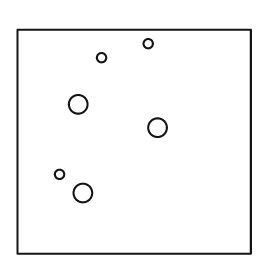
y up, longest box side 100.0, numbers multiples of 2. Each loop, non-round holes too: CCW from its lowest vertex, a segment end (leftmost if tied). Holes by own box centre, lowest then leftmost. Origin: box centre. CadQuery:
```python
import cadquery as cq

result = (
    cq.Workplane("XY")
    .moveTo(-50.0, -48.0)
    .lineTo(50.0, -48.0)
    .lineTo(50.0, 48.0)
    .lineTo(-50.0, 48.0)
    .close()
    .moveTo(-22.0, -22.0)
    .circle(4.0)
    .moveTo(-32.0, -14.0)
    .circle(2.0)
    .moveTo(10.0, 6.0)
    .circle(4.0)
    .moveTo(-24.0, 16.0)
    .circle(4.0)
    .moveTo(-14.0, 36.0)
    .circle(2.0)
    .moveTo(6.0, 42.0)
    .circle(2.0)
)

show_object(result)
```